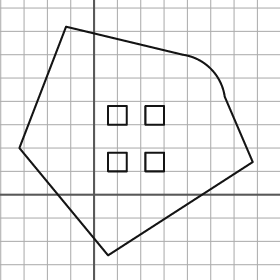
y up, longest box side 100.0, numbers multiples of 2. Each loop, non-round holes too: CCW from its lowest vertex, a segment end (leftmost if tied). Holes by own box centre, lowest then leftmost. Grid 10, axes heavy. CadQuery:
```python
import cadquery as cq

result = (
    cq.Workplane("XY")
    .moveTo(6.0, -26.0)
    .lineTo(68.0, 14.0)
    .lineTo(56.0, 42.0)
    .threePointArc((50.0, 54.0), (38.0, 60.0))
    .lineTo(-12.0, 72.0)
    .lineTo(-32.0, 20.0)
    .close()
    .moveTo(6.0, 10.0)
    .lineTo(14.0, 10.0)
    .lineTo(14.0, 18.0)
    .lineTo(6.0, 18.0)
    .close()
    .moveTo(22.0, 10.0)
    .lineTo(30.0, 10.0)
    .lineTo(30.0, 18.0)
    .lineTo(22.0, 18.0)
    .close()
    .moveTo(6.0, 30.0)
    .lineTo(14.0, 30.0)
    .lineTo(14.0, 38.0)
    .lineTo(6.0, 38.0)
    .close()
    .moveTo(22.0, 30.0)
    .lineTo(30.0, 30.0)
    .lineTo(30.0, 38.0)
    .lineTo(22.0, 38.0)
    .close()
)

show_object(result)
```